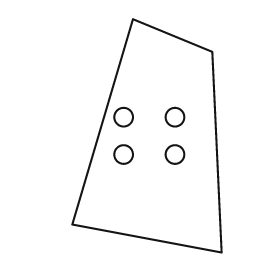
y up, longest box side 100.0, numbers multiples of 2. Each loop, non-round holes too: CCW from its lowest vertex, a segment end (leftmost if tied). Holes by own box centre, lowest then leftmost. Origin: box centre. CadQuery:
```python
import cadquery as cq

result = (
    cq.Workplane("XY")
    .moveTo(32.0, -50.0)
    .lineTo(28.0, 36.0)
    .lineTo(-6.0, 50.0)
    .lineTo(-32.0, -38.0)
    .close()
    .moveTo(-10.0, -8.0)
    .circle(4.0)
    .moveTo(12.0, -8.0)
    .circle(4.0)
    .moveTo(-10.0, 8.0)
    .circle(4.0)
    .moveTo(12.0, 8.0)
    .circle(4.0)
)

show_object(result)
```